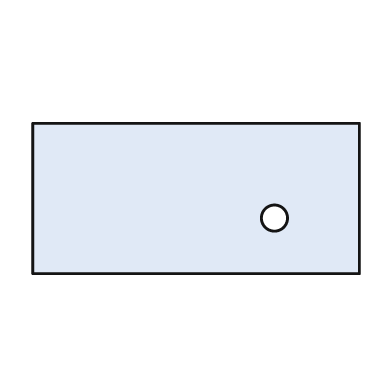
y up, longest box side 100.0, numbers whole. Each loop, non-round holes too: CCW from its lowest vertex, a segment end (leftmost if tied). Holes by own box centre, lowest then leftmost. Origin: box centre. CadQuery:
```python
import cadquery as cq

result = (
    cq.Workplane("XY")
    .moveTo(-50.0, -23.0)
    .lineTo(50.0, -23.0)
    .lineTo(50.0, 23.0)
    .lineTo(-50.0, 23.0)
    .close()
    .moveTo(24.0, -6.0)
    .circle(4.0)
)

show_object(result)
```